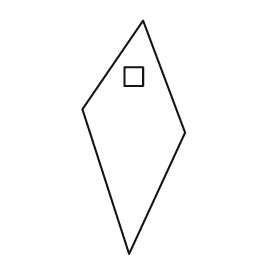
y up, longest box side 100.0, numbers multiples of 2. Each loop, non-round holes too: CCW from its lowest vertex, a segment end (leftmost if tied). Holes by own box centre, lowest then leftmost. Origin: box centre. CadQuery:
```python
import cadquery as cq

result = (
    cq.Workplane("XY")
    .moveTo(-2.0, -50.0)
    .lineTo(22.0, 2.0)
    .lineTo(4.0, 50.0)
    .lineTo(-22.0, 12.0)
    .close()
    .moveTo(-4.0, 22.0)
    .lineTo(4.0, 22.0)
    .lineTo(4.0, 30.0)
    .lineTo(-4.0, 30.0)
    .close()
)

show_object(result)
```